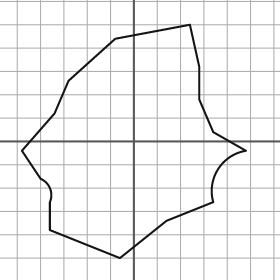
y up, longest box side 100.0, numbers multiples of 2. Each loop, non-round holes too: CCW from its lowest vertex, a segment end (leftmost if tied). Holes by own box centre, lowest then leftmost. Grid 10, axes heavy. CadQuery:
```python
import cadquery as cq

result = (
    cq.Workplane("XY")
    .moveTo(-6.0, -50.0)
    .lineTo(14.0, -34.0)
    .lineTo(34.0, -26.0)
    .threePointArc((36.0, -12.0), (48.0, -4.0))
    .lineTo(34.0, 4.0)
    .lineTo(28.0, 18.0)
    .lineTo(28.0, 32.0)
    .lineTo(24.0, 50.0)
    .lineTo(-8.0, 44.0)
    .lineTo(-28.0, 26.0)
    .lineTo(-34.0, 12.0)
    .lineTo(-48.0, -4.0)
    .lineTo(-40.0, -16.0)
    .threePointArc((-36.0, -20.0), (-36.0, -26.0))
    .lineTo(-36.0, -38.0)
    .close()
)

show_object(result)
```